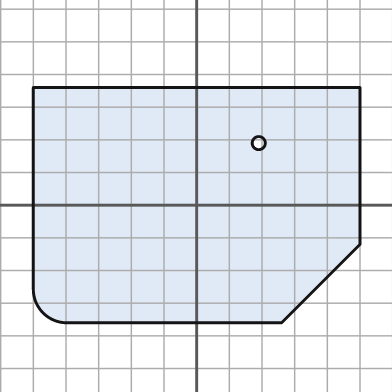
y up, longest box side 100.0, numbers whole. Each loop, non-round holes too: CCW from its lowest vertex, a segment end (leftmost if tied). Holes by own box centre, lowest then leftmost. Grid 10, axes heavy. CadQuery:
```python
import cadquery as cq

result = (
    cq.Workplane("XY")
    .moveTo(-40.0, -36.0)
    .lineTo(26.0, -36.0)
    .lineTo(50.0, -12.0)
    .lineTo(50.0, 36.0)
    .lineTo(-50.0, 36.0)
    .lineTo(-50.0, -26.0)
    .threePointArc((-47.0, -33.0), (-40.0, -36.0))
    .close()
    .moveTo(19.0, 19.0)
    .circle(2.0)
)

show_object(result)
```